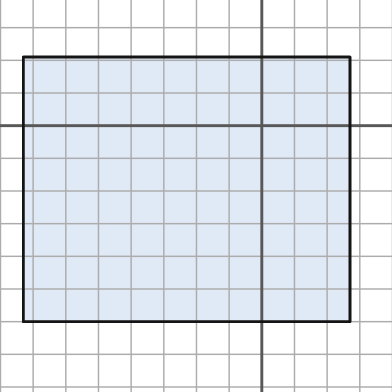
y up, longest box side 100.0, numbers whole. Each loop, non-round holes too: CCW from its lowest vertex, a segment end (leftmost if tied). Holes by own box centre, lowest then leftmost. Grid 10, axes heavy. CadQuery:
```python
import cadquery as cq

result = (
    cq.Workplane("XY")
    .moveTo(-73.0, -60.0)
    .lineTo(27.0, -60.0)
    .lineTo(27.0, 21.0)
    .lineTo(-73.0, 21.0)
    .close()
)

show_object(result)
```